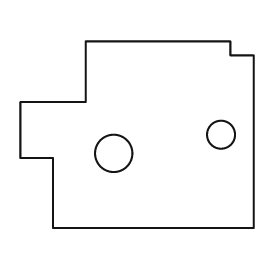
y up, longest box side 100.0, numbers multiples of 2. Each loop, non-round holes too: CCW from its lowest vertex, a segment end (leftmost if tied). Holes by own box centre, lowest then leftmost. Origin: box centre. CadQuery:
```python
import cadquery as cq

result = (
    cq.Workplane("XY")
    .moveTo(-36.0, -40.0)
    .lineTo(50.0, -40.0)
    .lineTo(50.0, 34.0)
    .lineTo(40.0, 34.0)
    .lineTo(40.0, 40.0)
    .lineTo(-22.0, 40.0)
    .lineTo(-22.0, 14.0)
    .lineTo(-50.0, 14.0)
    .lineTo(-50.0, -10.0)
    .lineTo(-36.0, -10.0)
    .close()
    .moveTo(-10.0, -8.0)
    .circle(8.0)
    .moveTo(36.0, 0.0)
    .circle(6.0)
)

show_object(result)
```